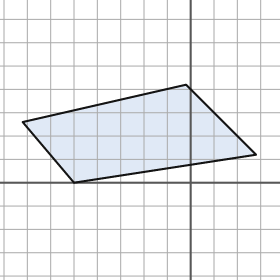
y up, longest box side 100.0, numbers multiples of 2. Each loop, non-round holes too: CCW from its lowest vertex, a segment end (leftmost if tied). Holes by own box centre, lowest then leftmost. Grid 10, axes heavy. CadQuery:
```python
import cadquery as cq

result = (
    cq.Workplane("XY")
    .moveTo(-50.0, 0.0)
    .lineTo(28.0, 12.0)
    .lineTo(-2.0, 42.0)
    .lineTo(-72.0, 26.0)
    .close()
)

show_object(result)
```